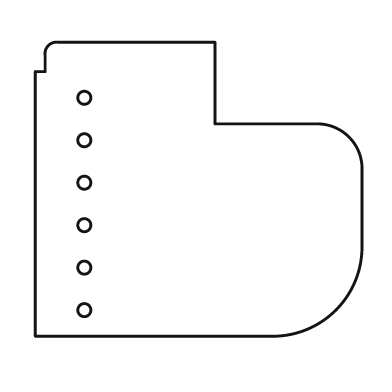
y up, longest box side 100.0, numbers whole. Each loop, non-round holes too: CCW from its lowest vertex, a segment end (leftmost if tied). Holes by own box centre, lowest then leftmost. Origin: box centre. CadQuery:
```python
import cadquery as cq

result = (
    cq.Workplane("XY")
    .moveTo(-50.0, -45.0)
    .lineTo(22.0, -45.0)
    .threePointArc((42.0, -37.0), (50.0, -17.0))
    .lineTo(50.0, 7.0)
    .threePointArc((46.0, 16.0), (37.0, 20.0))
    .lineTo(5.0, 20.0)
    .lineTo(5.0, 45.0)
    .lineTo(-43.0, 45.0)
    .threePointArc((-46.0, 44.0), (-47.0, 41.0))
    .lineTo(-47.0, 36.0)
    .lineTo(-50.0, 36.0)
    .close()
    .moveTo(-35.0, -37.0)
    .circle(2.0)
    .moveTo(-35.0, -24.0)
    .circle(2.0)
    .moveTo(-35.0, -11.0)
    .circle(2.0)
    .moveTo(-35.0, 2.0)
    .circle(2.0)
    .moveTo(-35.0, 15.0)
    .circle(2.0)
    .moveTo(-35.0, 28.0)
    .circle(2.0)
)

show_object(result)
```